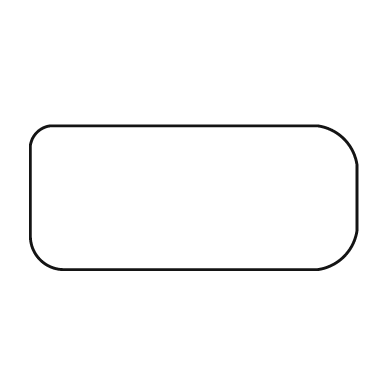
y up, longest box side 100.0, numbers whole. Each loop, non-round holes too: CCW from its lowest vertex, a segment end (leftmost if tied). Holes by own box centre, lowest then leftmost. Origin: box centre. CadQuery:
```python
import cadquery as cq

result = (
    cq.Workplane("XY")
    .moveTo(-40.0, -22.0)
    .lineTo(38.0, -22.0)
    .threePointArc((46.0, -18.0), (50.0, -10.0))
    .lineTo(50.0, 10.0)
    .threePointArc((46.0, 18.0), (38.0, 22.0))
    .lineTo(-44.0, 22.0)
    .threePointArc((-48.0, 20.0), (-50.0, 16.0))
    .lineTo(-50.0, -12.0)
    .threePointArc((-47.0, -19.0), (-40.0, -22.0))
    .close()
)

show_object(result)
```